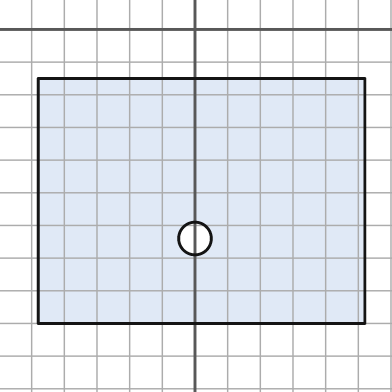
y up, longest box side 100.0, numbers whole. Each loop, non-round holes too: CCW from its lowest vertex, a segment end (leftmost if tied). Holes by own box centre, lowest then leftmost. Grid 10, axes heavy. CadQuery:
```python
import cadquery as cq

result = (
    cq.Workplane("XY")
    .moveTo(-48.0, -90.0)
    .lineTo(52.0, -90.0)
    .lineTo(52.0, -15.0)
    .lineTo(-48.0, -15.0)
    .close()
    .moveTo(0.0, -64.0)
    .circle(5.0)
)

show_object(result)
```